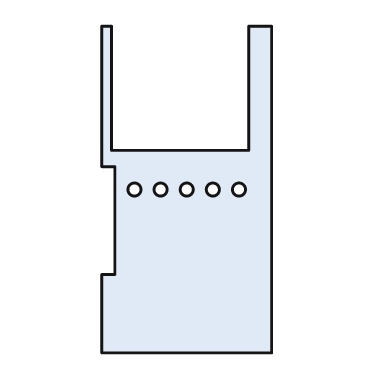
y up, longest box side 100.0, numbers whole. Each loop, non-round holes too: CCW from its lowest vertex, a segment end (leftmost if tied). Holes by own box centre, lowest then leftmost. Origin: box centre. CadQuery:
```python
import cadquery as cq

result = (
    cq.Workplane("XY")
    .moveTo(-26.0, -50.0)
    .lineTo(26.0, -50.0)
    .lineTo(26.0, 50.0)
    .lineTo(19.0, 50.0)
    .lineTo(19.0, 12.0)
    .lineTo(-23.0, 12.0)
    .lineTo(-23.0, 50.0)
    .lineTo(-26.0, 50.0)
    .lineTo(-26.0, 7.0)
    .lineTo(-22.0, 7.0)
    .lineTo(-22.0, -26.0)
    .lineTo(-26.0, -26.0)
    .close()
    .moveTo(-16.0, 0.0)
    .circle(2.0)
    .moveTo(-8.0, 0.0)
    .circle(2.0)
    .moveTo(0.0, 0.0)
    .circle(2.0)
    .moveTo(8.0, 0.0)
    .circle(2.0)
    .moveTo(16.0, 0.0)
    .circle(2.0)
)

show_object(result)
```